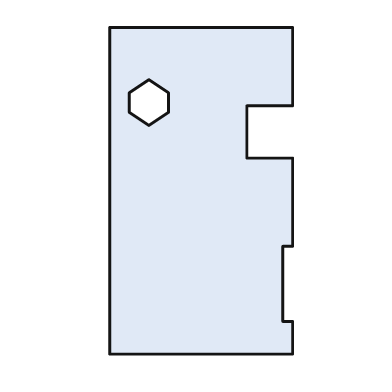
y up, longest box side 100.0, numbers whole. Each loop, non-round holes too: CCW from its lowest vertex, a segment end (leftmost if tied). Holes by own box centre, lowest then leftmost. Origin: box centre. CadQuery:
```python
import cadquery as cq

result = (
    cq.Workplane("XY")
    .moveTo(-28.0, -50.0)
    .lineTo(28.0, -50.0)
    .lineTo(28.0, -40.0)
    .lineTo(25.0, -40.0)
    .lineTo(25.0, -17.0)
    .lineTo(28.0, -17.0)
    .lineTo(28.0, 10.0)
    .lineTo(14.0, 10.0)
    .lineTo(14.0, 26.0)
    .lineTo(28.0, 26.0)
    .lineTo(28.0, 50.0)
    .lineTo(-28.0, 50.0)
    .close()
    .moveTo(-16.0, 20.0)
    .lineTo(-10.0, 24.0)
    .lineTo(-10.0, 30.0)
    .lineTo(-16.0, 34.0)
    .lineTo(-22.0, 30.0)
    .lineTo(-22.0, 24.0)
    .close()
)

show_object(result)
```